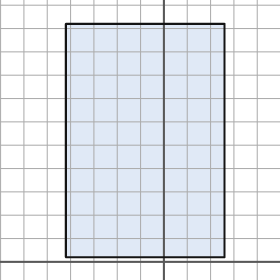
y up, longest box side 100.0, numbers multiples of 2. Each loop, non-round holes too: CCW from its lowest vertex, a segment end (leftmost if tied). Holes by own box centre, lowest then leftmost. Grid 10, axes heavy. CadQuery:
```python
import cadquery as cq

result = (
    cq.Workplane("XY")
    .moveTo(-42.0, 2.0)
    .lineTo(26.0, 2.0)
    .lineTo(26.0, 102.0)
    .lineTo(-42.0, 102.0)
    .close()
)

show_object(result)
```